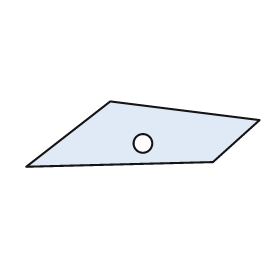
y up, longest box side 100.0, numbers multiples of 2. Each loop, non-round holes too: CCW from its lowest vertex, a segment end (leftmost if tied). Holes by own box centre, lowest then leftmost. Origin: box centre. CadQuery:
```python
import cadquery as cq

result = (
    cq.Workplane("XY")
    .moveTo(-50.0, -14.0)
    .lineTo(30.0, -12.0)
    .lineTo(50.0, 6.0)
    .lineTo(-14.0, 14.0)
    .close()
    .moveTo(0.0, -4.0)
    .circle(4.0)
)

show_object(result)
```